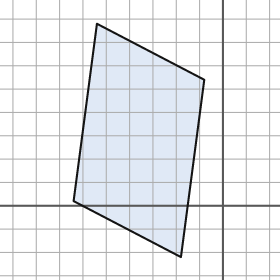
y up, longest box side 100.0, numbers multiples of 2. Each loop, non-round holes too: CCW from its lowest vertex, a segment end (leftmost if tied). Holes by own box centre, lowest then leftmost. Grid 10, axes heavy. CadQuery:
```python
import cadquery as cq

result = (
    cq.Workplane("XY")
    .moveTo(-18.0, -22.0)
    .lineTo(-8.0, 54.0)
    .lineTo(-54.0, 78.0)
    .lineTo(-64.0, 2.0)
    .close()
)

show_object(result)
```